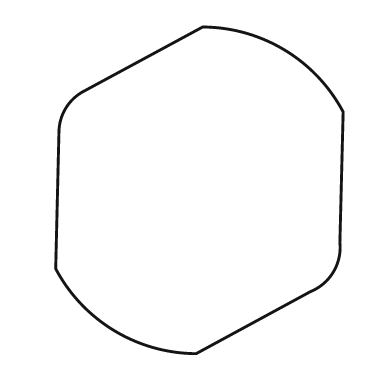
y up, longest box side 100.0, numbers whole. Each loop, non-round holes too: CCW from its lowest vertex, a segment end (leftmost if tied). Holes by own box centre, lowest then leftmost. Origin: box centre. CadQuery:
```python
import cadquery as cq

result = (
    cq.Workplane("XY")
    .moveTo(-1.0, -50.0)
    .lineTo(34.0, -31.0)
    .threePointArc((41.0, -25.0), (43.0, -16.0))
    .lineTo(44.0, 24.0)
    .threePointArc((26.0, 43.0), (1.0, 50.0))
    .lineTo(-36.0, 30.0)
    .threePointArc((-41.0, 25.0), (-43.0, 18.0))
    .lineTo(-44.0, -24.0)
    .threePointArc((-26.0, -43.0), (-1.0, -50.0))
    .close()
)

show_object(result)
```